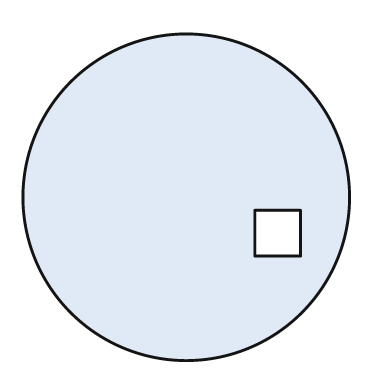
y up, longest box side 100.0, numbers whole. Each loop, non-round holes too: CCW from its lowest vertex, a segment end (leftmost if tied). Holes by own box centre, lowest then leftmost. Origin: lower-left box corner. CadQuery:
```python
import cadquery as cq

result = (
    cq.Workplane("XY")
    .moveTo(50.0, 50.0)
    .circle(50.0)
    .moveTo(71.0, 32.0)
    .lineTo(85.0, 32.0)
    .lineTo(85.0, 46.0)
    .lineTo(71.0, 46.0)
    .close()
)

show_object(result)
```